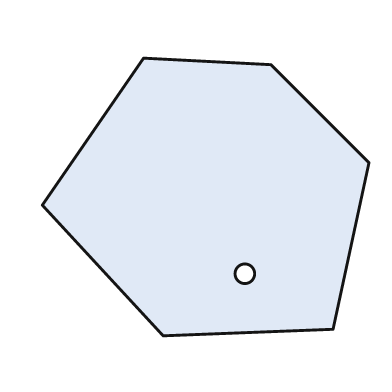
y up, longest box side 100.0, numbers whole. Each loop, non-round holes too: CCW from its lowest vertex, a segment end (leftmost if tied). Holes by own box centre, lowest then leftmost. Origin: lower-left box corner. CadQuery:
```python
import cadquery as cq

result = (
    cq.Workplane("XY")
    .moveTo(37.0, 0.0)
    .lineTo(89.0, 2.0)
    .lineTo(100.0, 53.0)
    .lineTo(70.0, 83.0)
    .lineTo(31.0, 85.0)
    .lineTo(0.0, 40.0)
    .close()
    .moveTo(62.0, 19.0)
    .circle(3.0)
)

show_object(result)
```